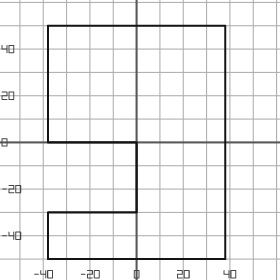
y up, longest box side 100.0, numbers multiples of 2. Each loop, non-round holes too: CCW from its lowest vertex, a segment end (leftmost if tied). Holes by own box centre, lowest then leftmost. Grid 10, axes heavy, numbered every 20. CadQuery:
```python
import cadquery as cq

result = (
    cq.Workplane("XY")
    .moveTo(-38.0, -50.0)
    .lineTo(38.0, -50.0)
    .lineTo(38.0, 50.0)
    .lineTo(-38.0, 50.0)
    .lineTo(-38.0, 0.0)
    .lineTo(0.0, 0.0)
    .lineTo(0.0, -30.0)
    .lineTo(-38.0, -30.0)
    .close()
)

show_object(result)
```